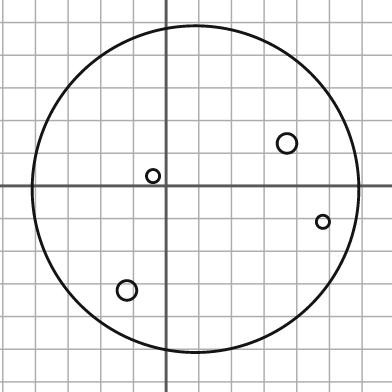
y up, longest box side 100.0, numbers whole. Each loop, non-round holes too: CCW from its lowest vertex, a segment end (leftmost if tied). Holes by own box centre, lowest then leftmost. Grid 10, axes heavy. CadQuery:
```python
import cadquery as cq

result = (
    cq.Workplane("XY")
    .moveTo(9.0, -1.0)
    .circle(50.0)
    .moveTo(-12.0, -32.0)
    .circle(3.0)
    .moveTo(48.0, -11.0)
    .circle(2.0)
    .moveTo(-4.0, 3.0)
    .circle(2.0)
    .moveTo(37.0, 13.0)
    .circle(3.0)
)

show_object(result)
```